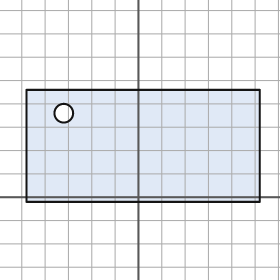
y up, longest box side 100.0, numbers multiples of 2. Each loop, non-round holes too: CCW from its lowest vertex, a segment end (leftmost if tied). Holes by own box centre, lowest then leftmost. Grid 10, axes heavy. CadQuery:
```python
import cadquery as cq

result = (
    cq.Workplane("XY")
    .moveTo(-48.0, -2.0)
    .lineTo(52.0, -2.0)
    .lineTo(52.0, 46.0)
    .lineTo(-48.0, 46.0)
    .close()
    .moveTo(-32.0, 36.0)
    .circle(4.0)
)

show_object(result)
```